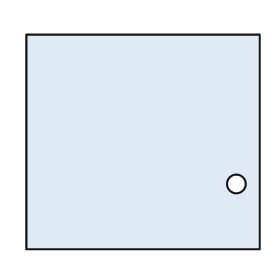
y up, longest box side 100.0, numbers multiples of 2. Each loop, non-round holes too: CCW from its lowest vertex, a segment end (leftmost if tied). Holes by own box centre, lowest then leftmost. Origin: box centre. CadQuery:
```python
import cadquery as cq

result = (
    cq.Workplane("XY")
    .moveTo(-50.0, -46.0)
    .lineTo(50.0, -46.0)
    .lineTo(50.0, 46.0)
    .lineTo(-50.0, 46.0)
    .close()
    .moveTo(40.0, -18.0)
    .circle(4.0)
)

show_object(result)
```